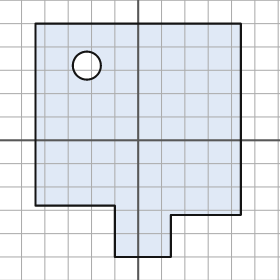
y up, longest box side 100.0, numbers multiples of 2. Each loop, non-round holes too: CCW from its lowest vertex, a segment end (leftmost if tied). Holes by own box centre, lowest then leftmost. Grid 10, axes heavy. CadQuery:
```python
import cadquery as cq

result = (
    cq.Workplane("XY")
    .moveTo(-10.0, -50.0)
    .lineTo(14.0, -50.0)
    .lineTo(14.0, -32.0)
    .lineTo(44.0, -32.0)
    .lineTo(44.0, 50.0)
    .lineTo(-44.0, 50.0)
    .lineTo(-44.0, -28.0)
    .lineTo(-10.0, -28.0)
    .close()
    .moveTo(-22.0, 32.0)
    .circle(6.0)
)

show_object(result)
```